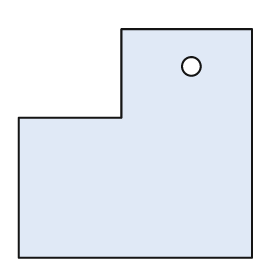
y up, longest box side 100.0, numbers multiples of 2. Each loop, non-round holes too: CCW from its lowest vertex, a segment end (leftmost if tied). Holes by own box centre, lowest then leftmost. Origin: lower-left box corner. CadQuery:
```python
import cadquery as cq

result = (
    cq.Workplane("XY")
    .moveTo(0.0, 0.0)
    .lineTo(100.0, 0.0)
    .lineTo(100.0, 98.0)
    .lineTo(44.0, 98.0)
    .lineTo(44.0, 60.0)
    .lineTo(0.0, 60.0)
    .close()
    .moveTo(74.0, 82.0)
    .circle(4.0)
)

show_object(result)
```